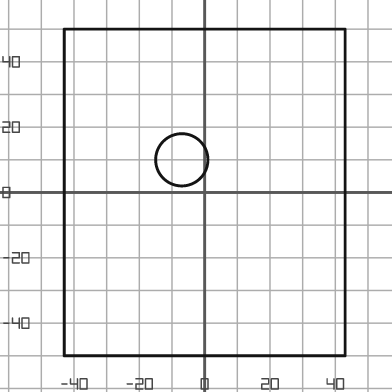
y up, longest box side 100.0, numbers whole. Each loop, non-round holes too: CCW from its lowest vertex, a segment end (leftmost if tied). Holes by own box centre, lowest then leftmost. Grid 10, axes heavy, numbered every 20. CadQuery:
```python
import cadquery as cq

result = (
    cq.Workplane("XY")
    .moveTo(-43.0, -50.0)
    .lineTo(43.0, -50.0)
    .lineTo(43.0, 50.0)
    .lineTo(-43.0, 50.0)
    .close()
    .moveTo(-7.0, 10.0)
    .circle(8.0)
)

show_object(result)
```